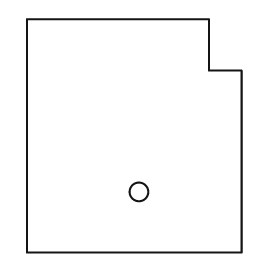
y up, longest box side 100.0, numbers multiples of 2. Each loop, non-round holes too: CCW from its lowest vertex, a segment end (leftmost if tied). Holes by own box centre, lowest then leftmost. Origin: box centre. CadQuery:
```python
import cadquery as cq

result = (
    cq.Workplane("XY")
    .moveTo(-46.0, -50.0)
    .lineTo(46.0, -50.0)
    .lineTo(46.0, 28.0)
    .lineTo(32.0, 28.0)
    .lineTo(32.0, 50.0)
    .lineTo(-46.0, 50.0)
    .close()
    .moveTo(2.0, -24.0)
    .circle(4.0)
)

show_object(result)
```